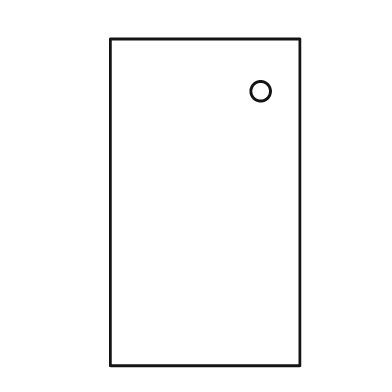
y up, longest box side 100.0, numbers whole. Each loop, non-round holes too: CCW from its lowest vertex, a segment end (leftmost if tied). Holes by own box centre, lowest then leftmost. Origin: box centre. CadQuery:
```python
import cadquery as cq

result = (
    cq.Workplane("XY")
    .moveTo(-29.0, -50.0)
    .lineTo(29.0, -50.0)
    .lineTo(29.0, 50.0)
    .lineTo(-29.0, 50.0)
    .close()
    .moveTo(17.0, 34.0)
    .circle(3.0)
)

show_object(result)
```